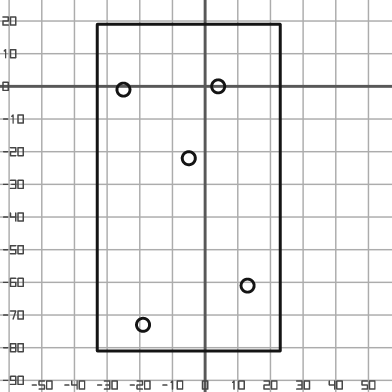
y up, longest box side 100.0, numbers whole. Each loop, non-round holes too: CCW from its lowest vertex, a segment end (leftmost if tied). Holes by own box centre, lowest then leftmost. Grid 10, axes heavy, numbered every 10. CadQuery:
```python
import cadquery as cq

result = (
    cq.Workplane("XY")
    .moveTo(-33.0, -81.0)
    .lineTo(23.0, -81.0)
    .lineTo(23.0, 19.0)
    .lineTo(-33.0, 19.0)
    .close()
    .moveTo(-19.0, -73.0)
    .circle(2.0)
    .moveTo(13.0, -61.0)
    .circle(2.0)
    .moveTo(-5.0, -22.0)
    .circle(2.0)
    .moveTo(-25.0, -1.0)
    .circle(2.0)
    .moveTo(4.0, 0.0)
    .circle(2.0)
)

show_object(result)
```